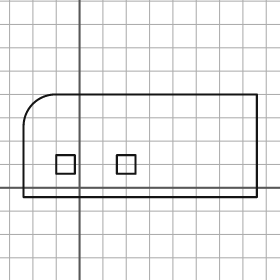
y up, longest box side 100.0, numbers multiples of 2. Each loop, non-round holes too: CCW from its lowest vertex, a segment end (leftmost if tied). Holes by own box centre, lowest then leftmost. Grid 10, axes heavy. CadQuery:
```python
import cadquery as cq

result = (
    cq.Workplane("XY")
    .moveTo(-24.0, -4.0)
    .lineTo(76.0, -4.0)
    .lineTo(76.0, 40.0)
    .lineTo(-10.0, 40.0)
    .threePointArc((-20.0, 36.0), (-24.0, 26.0))
    .close()
    .moveTo(-10.0, 6.0)
    .lineTo(-2.0, 6.0)
    .lineTo(-2.0, 14.0)
    .lineTo(-10.0, 14.0)
    .close()
    .moveTo(16.0, 6.0)
    .lineTo(24.0, 6.0)
    .lineTo(24.0, 14.0)
    .lineTo(16.0, 14.0)
    .close()
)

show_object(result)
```